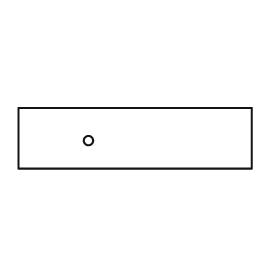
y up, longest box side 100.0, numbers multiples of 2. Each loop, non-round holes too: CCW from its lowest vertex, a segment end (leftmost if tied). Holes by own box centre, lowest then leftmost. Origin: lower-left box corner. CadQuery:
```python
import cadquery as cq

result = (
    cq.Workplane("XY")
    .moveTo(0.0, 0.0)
    .lineTo(100.0, 0.0)
    .lineTo(100.0, 26.0)
    .lineTo(0.0, 26.0)
    .close()
    .moveTo(30.0, 12.0)
    .circle(2.0)
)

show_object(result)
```